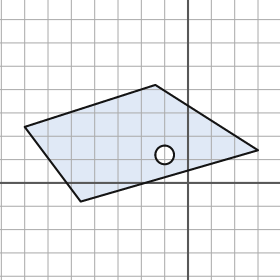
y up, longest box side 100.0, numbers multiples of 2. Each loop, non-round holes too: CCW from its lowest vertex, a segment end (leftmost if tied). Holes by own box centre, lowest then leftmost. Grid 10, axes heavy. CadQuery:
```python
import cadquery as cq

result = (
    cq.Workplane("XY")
    .moveTo(-46.0, -8.0)
    .lineTo(30.0, 14.0)
    .lineTo(-14.0, 42.0)
    .lineTo(-70.0, 24.0)
    .close()
    .moveTo(-10.0, 12.0)
    .circle(4.0)
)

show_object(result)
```